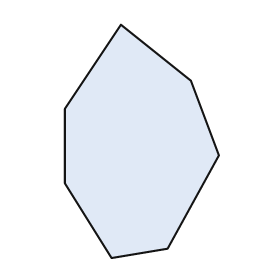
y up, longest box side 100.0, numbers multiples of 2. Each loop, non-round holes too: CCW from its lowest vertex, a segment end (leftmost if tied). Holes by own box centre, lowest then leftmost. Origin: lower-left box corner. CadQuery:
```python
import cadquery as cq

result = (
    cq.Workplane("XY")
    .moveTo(20.0, 0.0)
    .lineTo(44.0, 4.0)
    .lineTo(66.0, 44.0)
    .lineTo(54.0, 76.0)
    .lineTo(24.0, 100.0)
    .lineTo(0.0, 64.0)
    .lineTo(0.0, 32.0)
    .close()
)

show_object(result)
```